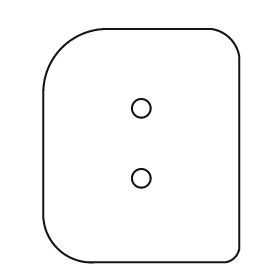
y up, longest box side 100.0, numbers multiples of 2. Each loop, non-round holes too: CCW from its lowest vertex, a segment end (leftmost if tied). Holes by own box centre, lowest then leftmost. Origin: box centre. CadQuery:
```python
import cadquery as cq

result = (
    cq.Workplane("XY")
    .moveTo(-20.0, -50.0)
    .lineTo(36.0, -50.0)
    .threePointArc((40.0, -48.0), (42.0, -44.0))
    .lineTo(42.0, 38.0)
    .threePointArc((38.0, 46.0), (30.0, 50.0))
    .lineTo(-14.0, 50.0)
    .threePointArc((-34.0, 42.0), (-42.0, 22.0))
    .lineTo(-42.0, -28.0)
    .threePointArc((-36.0, -44.0), (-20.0, -50.0))
    .close()
    .moveTo(0.0, -14.0)
    .circle(4.0)
    .moveTo(0.0, 16.0)
    .circle(4.0)
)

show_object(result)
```